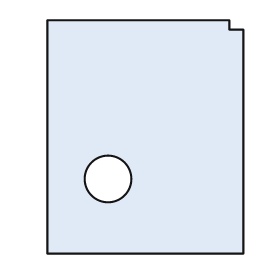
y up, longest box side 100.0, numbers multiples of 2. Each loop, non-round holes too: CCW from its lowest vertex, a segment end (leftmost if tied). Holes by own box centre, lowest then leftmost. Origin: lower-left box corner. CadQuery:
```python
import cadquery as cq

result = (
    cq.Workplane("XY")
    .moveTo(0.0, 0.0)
    .lineTo(84.0, 0.0)
    .lineTo(84.0, 96.0)
    .lineTo(78.0, 96.0)
    .lineTo(78.0, 100.0)
    .lineTo(0.0, 100.0)
    .close()
    .moveTo(26.0, 32.0)
    .circle(10.0)
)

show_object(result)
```